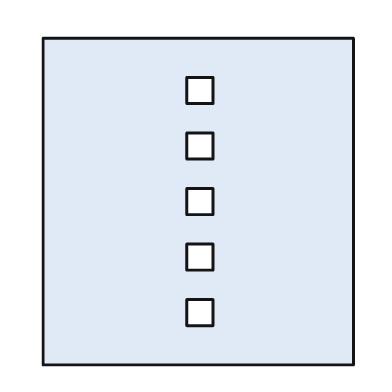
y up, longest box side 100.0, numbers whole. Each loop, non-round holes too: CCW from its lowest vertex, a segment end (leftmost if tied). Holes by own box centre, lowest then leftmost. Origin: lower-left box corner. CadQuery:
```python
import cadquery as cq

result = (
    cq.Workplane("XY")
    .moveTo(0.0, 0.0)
    .lineTo(95.0, 0.0)
    .lineTo(95.0, 100.0)
    .lineTo(0.0, 100.0)
    .close()
    .moveTo(44.0, 12.0)
    .lineTo(52.0, 12.0)
    .lineTo(52.0, 20.0)
    .lineTo(44.0, 20.0)
    .close()
    .moveTo(44.0, 29.0)
    .lineTo(52.0, 29.0)
    .lineTo(52.0, 37.0)
    .lineTo(44.0, 37.0)
    .close()
    .moveTo(44.0, 46.0)
    .lineTo(52.0, 46.0)
    .lineTo(52.0, 54.0)
    .lineTo(44.0, 54.0)
    .close()
    .moveTo(44.0, 63.0)
    .lineTo(52.0, 63.0)
    .lineTo(52.0, 71.0)
    .lineTo(44.0, 71.0)
    .close()
    .moveTo(44.0, 80.0)
    .lineTo(52.0, 80.0)
    .lineTo(52.0, 88.0)
    .lineTo(44.0, 88.0)
    .close()
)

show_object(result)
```